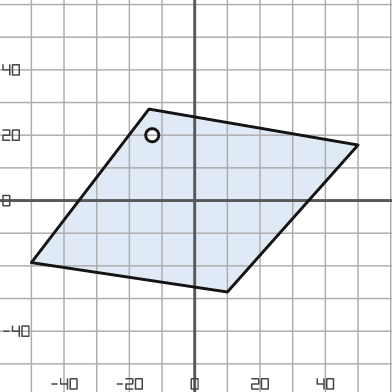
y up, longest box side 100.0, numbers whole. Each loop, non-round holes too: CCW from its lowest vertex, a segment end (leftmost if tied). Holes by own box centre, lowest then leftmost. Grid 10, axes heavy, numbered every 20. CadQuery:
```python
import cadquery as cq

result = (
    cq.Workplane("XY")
    .moveTo(10.0, -28.0)
    .lineTo(50.0, 17.0)
    .lineTo(-14.0, 28.0)
    .lineTo(-50.0, -19.0)
    .close()
    .moveTo(-13.0, 20.0)
    .circle(2.0)
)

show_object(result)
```